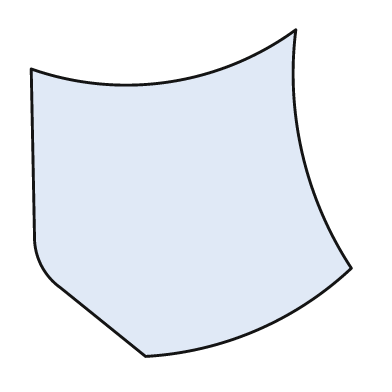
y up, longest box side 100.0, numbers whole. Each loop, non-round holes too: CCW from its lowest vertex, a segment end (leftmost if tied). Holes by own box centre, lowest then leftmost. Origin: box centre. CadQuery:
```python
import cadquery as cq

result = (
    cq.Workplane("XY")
    .moveTo(-14.0, -50.0)
    .threePointArc((20.0, -42.0), (49.0, -23.0))
    .threePointArc((34.0, 12.0), (32.0, 50.0))
    .threePointArc((-7.0, 34.0), (-49.0, 38.0))
    .lineTo(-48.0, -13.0)
    .threePointArc((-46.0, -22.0), (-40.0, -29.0))
    .close()
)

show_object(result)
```